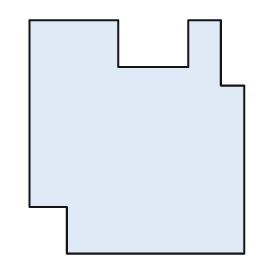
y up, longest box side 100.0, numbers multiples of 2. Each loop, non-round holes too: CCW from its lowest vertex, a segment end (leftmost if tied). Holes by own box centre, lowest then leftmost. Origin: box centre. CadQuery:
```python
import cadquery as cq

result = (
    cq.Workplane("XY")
    .moveTo(-30.0, -50.0)
    .lineTo(46.0, -50.0)
    .lineTo(46.0, 22.0)
    .lineTo(36.0, 22.0)
    .lineTo(36.0, 50.0)
    .lineTo(22.0, 50.0)
    .lineTo(22.0, 30.0)
    .lineTo(-8.0, 30.0)
    .lineTo(-8.0, 50.0)
    .lineTo(-46.0, 50.0)
    .lineTo(-46.0, -30.0)
    .lineTo(-30.0, -30.0)
    .close()
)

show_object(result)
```